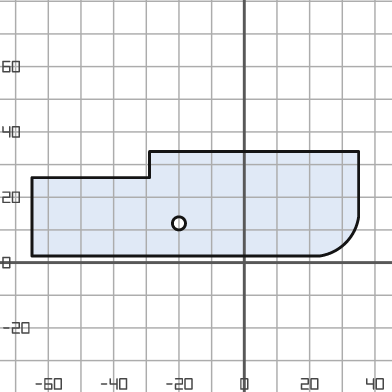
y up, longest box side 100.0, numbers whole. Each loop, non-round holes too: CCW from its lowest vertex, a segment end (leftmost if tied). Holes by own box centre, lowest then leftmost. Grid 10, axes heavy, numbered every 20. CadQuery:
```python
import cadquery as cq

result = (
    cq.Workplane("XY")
    .moveTo(-65.0, 2.0)
    .lineTo(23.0, 2.0)
    .threePointArc((31.0, 6.0), (35.0, 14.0))
    .lineTo(35.0, 34.0)
    .lineTo(-29.0, 34.0)
    .lineTo(-29.0, 26.0)
    .lineTo(-65.0, 26.0)
    .close()
    .moveTo(-20.0, 12.0)
    .circle(2.0)
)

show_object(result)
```